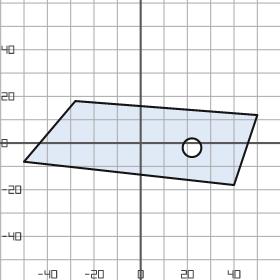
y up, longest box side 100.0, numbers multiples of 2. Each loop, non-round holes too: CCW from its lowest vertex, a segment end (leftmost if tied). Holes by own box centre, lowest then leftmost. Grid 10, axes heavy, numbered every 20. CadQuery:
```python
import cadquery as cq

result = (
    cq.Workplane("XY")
    .moveTo(40.0, -18.0)
    .lineTo(50.0, 12.0)
    .lineTo(-28.0, 18.0)
    .lineTo(-50.0, -8.0)
    .close()
    .moveTo(22.0, -2.0)
    .circle(4.0)
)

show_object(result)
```